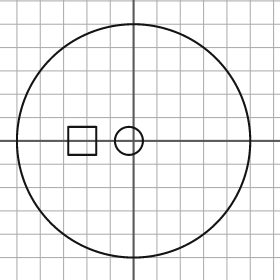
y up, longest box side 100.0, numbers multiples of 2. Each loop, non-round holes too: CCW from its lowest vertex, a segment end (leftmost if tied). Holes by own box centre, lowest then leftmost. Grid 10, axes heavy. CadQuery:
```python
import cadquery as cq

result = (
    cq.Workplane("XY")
    .moveTo(0.0, 0.0)
    .circle(50.0)
    .moveTo(-28.0, -6.0)
    .lineTo(-16.0, -6.0)
    .lineTo(-16.0, 6.0)
    .lineTo(-28.0, 6.0)
    .close()
    .moveTo(-2.0, 0.0)
    .circle(6.0)
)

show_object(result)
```